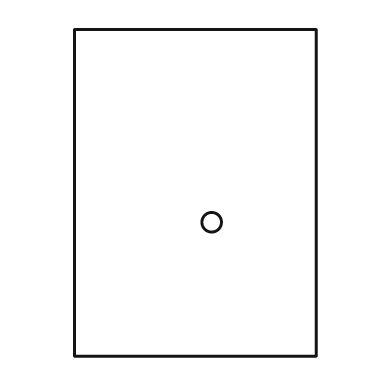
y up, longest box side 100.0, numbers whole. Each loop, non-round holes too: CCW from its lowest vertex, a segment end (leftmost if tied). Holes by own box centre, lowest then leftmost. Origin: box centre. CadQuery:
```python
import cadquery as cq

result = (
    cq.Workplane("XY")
    .moveTo(-37.0, -50.0)
    .lineTo(37.0, -50.0)
    .lineTo(37.0, 50.0)
    .lineTo(-37.0, 50.0)
    .close()
    .moveTo(5.0, -9.0)
    .circle(3.0)
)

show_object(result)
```